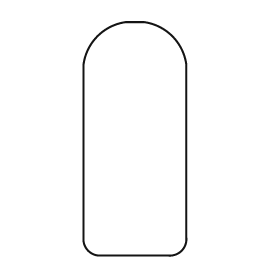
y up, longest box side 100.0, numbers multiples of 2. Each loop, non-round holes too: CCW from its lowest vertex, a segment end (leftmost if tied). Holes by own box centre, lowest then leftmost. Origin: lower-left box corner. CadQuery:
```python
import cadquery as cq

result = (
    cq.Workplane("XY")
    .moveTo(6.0, 0.0)
    .lineTo(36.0, 0.0)
    .threePointArc((42.0, 2.0), (44.0, 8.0))
    .lineTo(44.0, 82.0)
    .threePointArc((38.0, 94.0), (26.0, 100.0))
    .lineTo(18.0, 100.0)
    .threePointArc((6.0, 94.0), (0.0, 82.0))
    .lineTo(0.0, 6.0)
    .threePointArc((2.0, 2.0), (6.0, 0.0))
    .close()
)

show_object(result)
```